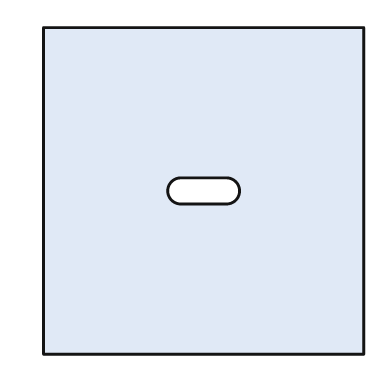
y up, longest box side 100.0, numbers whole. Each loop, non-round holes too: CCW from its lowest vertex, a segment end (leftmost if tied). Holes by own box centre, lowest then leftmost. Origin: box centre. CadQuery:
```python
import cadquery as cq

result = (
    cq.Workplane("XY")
    .moveTo(-49.0, -50.0)
    .lineTo(49.0, -50.0)
    .lineTo(49.0, 50.0)
    .lineTo(-49.0, 50.0)
    .close()
    .moveTo(-7.0, -4.0)
    .lineTo(7.0, -4.0)
    .threePointArc((11.0, 0.0), (7.0, 4.0))
    .lineTo(-7.0, 4.0)
    .threePointArc((-11.0, 0.0), (-7.0, -4.0))
    .close()
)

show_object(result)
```